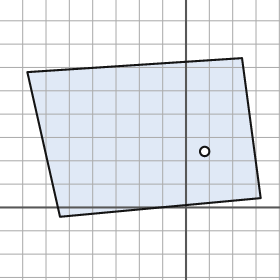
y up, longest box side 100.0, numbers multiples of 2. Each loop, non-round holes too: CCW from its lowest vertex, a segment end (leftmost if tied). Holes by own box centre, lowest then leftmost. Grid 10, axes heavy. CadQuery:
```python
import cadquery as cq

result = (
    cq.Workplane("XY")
    .moveTo(-54.0, -4.0)
    .lineTo(32.0, 4.0)
    .lineTo(24.0, 64.0)
    .lineTo(-68.0, 58.0)
    .close()
    .moveTo(8.0, 24.0)
    .circle(2.0)
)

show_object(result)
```